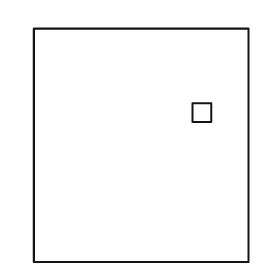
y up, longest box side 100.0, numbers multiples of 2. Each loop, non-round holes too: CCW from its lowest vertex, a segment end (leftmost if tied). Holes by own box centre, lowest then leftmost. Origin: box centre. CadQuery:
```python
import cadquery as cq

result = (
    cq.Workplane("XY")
    .moveTo(-46.0, -50.0)
    .lineTo(46.0, -50.0)
    .lineTo(46.0, 50.0)
    .lineTo(-46.0, 50.0)
    .close()
    .moveTo(22.0, 10.0)
    .lineTo(30.0, 10.0)
    .lineTo(30.0, 18.0)
    .lineTo(22.0, 18.0)
    .close()
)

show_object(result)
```